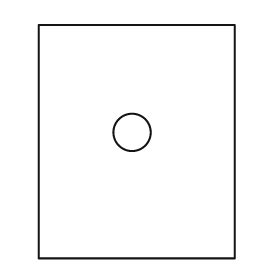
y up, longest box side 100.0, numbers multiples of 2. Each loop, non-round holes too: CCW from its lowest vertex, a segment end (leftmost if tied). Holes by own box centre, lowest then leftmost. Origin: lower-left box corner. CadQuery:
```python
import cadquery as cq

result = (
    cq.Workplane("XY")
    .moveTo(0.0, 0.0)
    .lineTo(84.0, 0.0)
    .lineTo(84.0, 100.0)
    .lineTo(0.0, 100.0)
    .close()
    .moveTo(40.0, 54.0)
    .circle(8.0)
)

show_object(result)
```